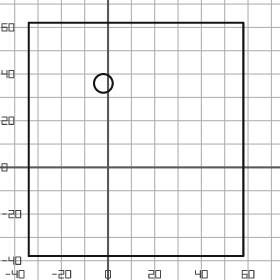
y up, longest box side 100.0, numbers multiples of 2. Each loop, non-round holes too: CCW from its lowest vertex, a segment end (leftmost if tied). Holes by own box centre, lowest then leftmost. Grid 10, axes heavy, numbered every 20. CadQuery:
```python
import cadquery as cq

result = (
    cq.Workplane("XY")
    .moveTo(-34.0, -38.0)
    .lineTo(58.0, -38.0)
    .lineTo(58.0, 62.0)
    .lineTo(-34.0, 62.0)
    .close()
    .moveTo(-2.0, 36.0)
    .circle(4.0)
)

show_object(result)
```